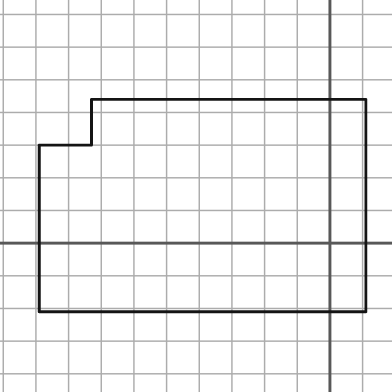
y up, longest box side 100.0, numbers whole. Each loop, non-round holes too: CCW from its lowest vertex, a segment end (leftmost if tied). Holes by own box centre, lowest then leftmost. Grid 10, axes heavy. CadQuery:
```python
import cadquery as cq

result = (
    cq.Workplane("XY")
    .moveTo(-89.0, -21.0)
    .lineTo(11.0, -21.0)
    .lineTo(11.0, 44.0)
    .lineTo(-73.0, 44.0)
    .lineTo(-73.0, 30.0)
    .lineTo(-89.0, 30.0)
    .close()
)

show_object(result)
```